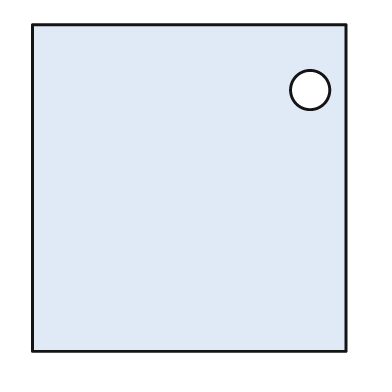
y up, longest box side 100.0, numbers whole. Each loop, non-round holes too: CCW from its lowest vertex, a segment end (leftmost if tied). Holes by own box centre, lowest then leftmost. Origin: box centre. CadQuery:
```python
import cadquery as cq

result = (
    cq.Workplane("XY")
    .moveTo(-48.0, -50.0)
    .lineTo(48.0, -50.0)
    .lineTo(48.0, 50.0)
    .lineTo(-48.0, 50.0)
    .close()
    .moveTo(37.0, 30.0)
    .circle(6.0)
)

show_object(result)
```